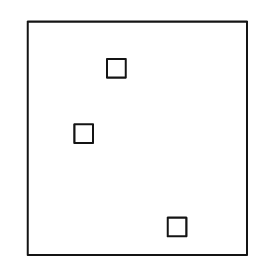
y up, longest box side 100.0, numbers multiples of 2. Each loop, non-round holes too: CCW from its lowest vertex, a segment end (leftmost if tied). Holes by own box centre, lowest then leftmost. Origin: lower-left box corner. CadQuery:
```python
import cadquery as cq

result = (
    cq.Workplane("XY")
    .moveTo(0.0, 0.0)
    .lineTo(94.0, 0.0)
    .lineTo(94.0, 100.0)
    .lineTo(0.0, 100.0)
    .close()
    .moveTo(60.0, 8.0)
    .lineTo(68.0, 8.0)
    .lineTo(68.0, 16.0)
    .lineTo(60.0, 16.0)
    .close()
    .moveTo(20.0, 48.0)
    .lineTo(28.0, 48.0)
    .lineTo(28.0, 56.0)
    .lineTo(20.0, 56.0)
    .close()
    .moveTo(34.0, 76.0)
    .lineTo(42.0, 76.0)
    .lineTo(42.0, 84.0)
    .lineTo(34.0, 84.0)
    .close()
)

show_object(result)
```